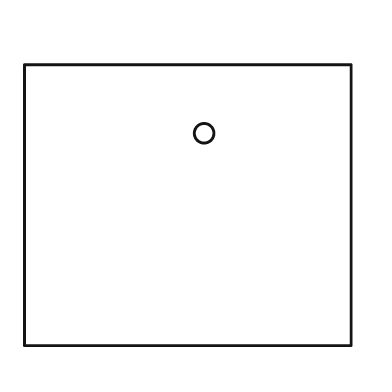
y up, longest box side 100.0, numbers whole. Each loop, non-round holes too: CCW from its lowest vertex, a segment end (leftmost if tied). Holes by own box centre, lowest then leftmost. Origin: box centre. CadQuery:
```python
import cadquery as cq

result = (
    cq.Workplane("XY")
    .moveTo(-50.0, -43.0)
    .lineTo(50.0, -43.0)
    .lineTo(50.0, 43.0)
    .lineTo(-50.0, 43.0)
    .close()
    .moveTo(5.0, 22.0)
    .circle(3.0)
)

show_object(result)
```